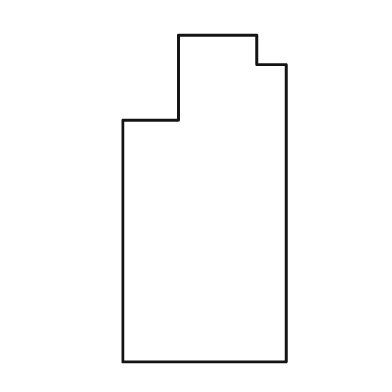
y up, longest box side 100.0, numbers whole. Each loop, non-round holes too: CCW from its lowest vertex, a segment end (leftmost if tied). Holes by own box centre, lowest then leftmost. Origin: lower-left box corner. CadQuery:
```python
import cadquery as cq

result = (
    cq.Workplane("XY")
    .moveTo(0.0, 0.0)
    .lineTo(50.0, 0.0)
    .lineTo(50.0, 91.0)
    .lineTo(41.0, 91.0)
    .lineTo(41.0, 100.0)
    .lineTo(17.0, 100.0)
    .lineTo(17.0, 74.0)
    .lineTo(0.0, 74.0)
    .close()
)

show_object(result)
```